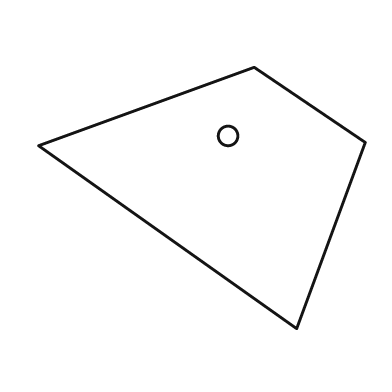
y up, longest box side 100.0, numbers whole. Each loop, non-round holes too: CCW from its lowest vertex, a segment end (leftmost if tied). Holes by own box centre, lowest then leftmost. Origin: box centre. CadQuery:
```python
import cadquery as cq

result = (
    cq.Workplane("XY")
    .moveTo(29.0, -40.0)
    .lineTo(50.0, 17.0)
    .lineTo(16.0, 40.0)
    .lineTo(-50.0, 16.0)
    .close()
    .moveTo(8.0, 19.0)
    .circle(3.0)
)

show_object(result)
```